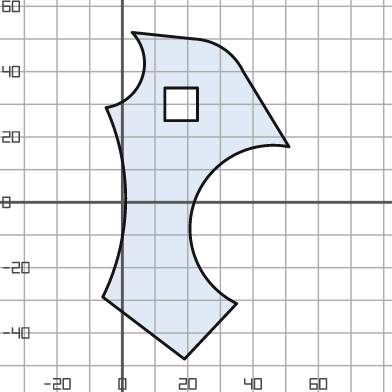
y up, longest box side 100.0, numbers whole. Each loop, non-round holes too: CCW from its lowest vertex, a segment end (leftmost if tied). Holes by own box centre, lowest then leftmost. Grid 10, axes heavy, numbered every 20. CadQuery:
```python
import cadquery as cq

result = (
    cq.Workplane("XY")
    .moveTo(19.0, -48.0)
    .lineTo(35.0, -31.0)
    .threePointArc((22.0, 0.0), (51.0, 17.0))
    .lineTo(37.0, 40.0)
    .threePointArc((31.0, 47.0), (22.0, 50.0))
    .lineTo(3.0, 52.0)
    .threePointArc((6.0, 38.0), (-5.0, 29.0))
    .threePointArc((1.0, 0.0), (-6.0, -29.0))
    .close()
    .moveTo(13.0, 25.0)
    .lineTo(23.0, 25.0)
    .lineTo(23.0, 35.0)
    .lineTo(13.0, 35.0)
    .close()
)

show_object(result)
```